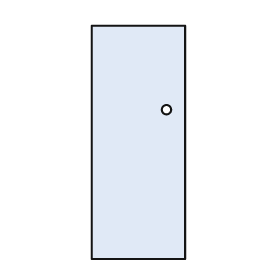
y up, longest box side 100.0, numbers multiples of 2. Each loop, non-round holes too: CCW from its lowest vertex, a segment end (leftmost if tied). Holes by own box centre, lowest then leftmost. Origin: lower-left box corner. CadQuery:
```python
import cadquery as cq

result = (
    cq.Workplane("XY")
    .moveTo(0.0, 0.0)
    .lineTo(40.0, 0.0)
    .lineTo(40.0, 100.0)
    .lineTo(0.0, 100.0)
    .close()
    .moveTo(32.0, 64.0)
    .circle(2.0)
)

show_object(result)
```